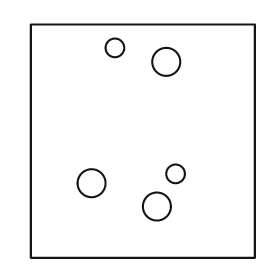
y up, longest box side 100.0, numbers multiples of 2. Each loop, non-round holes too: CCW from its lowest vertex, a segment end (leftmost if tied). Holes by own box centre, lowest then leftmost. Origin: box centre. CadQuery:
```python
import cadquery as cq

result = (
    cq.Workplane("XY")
    .moveTo(-48.0, -50.0)
    .lineTo(48.0, -50.0)
    .lineTo(48.0, 50.0)
    .lineTo(-48.0, 50.0)
    .close()
    .moveTo(6.0, -28.0)
    .circle(6.0)
    .moveTo(-22.0, -18.0)
    .circle(6.0)
    .moveTo(14.0, -14.0)
    .circle(4.0)
    .moveTo(10.0, 34.0)
    .circle(6.0)
    .moveTo(-12.0, 40.0)
    .circle(4.0)
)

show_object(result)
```